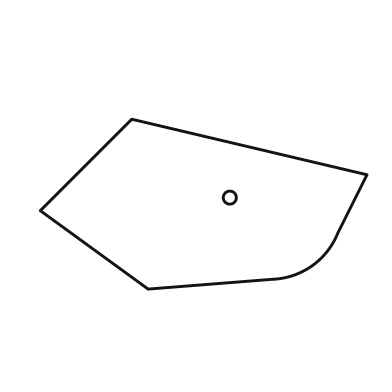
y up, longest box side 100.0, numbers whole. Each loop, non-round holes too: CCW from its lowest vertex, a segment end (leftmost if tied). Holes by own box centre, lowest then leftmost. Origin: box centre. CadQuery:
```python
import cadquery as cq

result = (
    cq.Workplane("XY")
    .moveTo(-17.0, -26.0)
    .lineTo(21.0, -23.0)
    .threePointArc((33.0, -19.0), (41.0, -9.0))
    .lineTo(50.0, 9.0)
    .lineTo(-22.0, 26.0)
    .lineTo(-50.0, -2.0)
    .close()
    .moveTo(8.0, 2.0)
    .circle(2.0)
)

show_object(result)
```